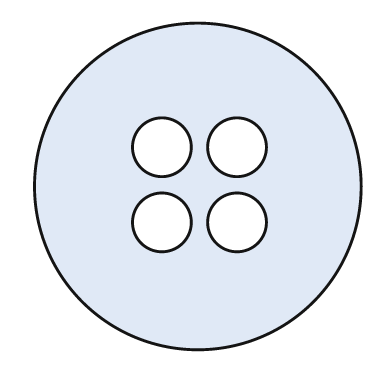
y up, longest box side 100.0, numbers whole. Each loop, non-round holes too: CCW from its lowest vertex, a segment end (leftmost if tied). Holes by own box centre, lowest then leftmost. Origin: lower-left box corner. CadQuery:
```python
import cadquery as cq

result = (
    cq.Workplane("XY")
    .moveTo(50.0, 50.0)
    .circle(50.0)
    .moveTo(39.0, 39.0)
    .circle(9.0)
    .moveTo(62.0, 39.0)
    .circle(9.0)
    .moveTo(39.0, 62.0)
    .circle(9.0)
    .moveTo(62.0, 62.0)
    .circle(9.0)
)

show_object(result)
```